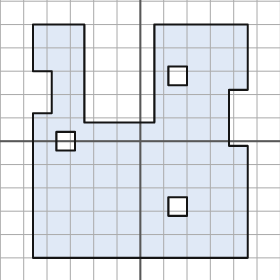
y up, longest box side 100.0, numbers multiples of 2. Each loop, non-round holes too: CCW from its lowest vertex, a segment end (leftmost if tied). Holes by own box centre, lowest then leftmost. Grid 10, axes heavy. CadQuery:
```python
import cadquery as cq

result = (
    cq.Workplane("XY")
    .moveTo(-46.0, -50.0)
    .lineTo(46.0, -50.0)
    .lineTo(46.0, -2.0)
    .lineTo(38.0, -2.0)
    .lineTo(38.0, 22.0)
    .lineTo(46.0, 22.0)
    .lineTo(46.0, 50.0)
    .lineTo(6.0, 50.0)
    .lineTo(6.0, 8.0)
    .lineTo(-24.0, 8.0)
    .lineTo(-24.0, 50.0)
    .lineTo(-46.0, 50.0)
    .lineTo(-46.0, 30.0)
    .lineTo(-38.0, 30.0)
    .lineTo(-38.0, 12.0)
    .lineTo(-46.0, 12.0)
    .close()
    .moveTo(12.0, -32.0)
    .lineTo(20.0, -32.0)
    .lineTo(20.0, -24.0)
    .lineTo(12.0, -24.0)
    .close()
    .moveTo(-36.0, -4.0)
    .lineTo(-28.0, -4.0)
    .lineTo(-28.0, 4.0)
    .lineTo(-36.0, 4.0)
    .close()
    .moveTo(12.0, 24.0)
    .lineTo(20.0, 24.0)
    .lineTo(20.0, 32.0)
    .lineTo(12.0, 32.0)
    .close()
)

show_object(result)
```